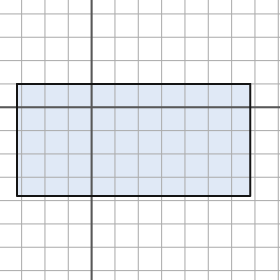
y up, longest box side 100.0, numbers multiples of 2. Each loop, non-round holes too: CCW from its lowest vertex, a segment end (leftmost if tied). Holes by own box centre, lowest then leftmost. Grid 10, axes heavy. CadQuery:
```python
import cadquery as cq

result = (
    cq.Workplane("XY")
    .moveTo(-32.0, -38.0)
    .lineTo(68.0, -38.0)
    .lineTo(68.0, 10.0)
    .lineTo(-32.0, 10.0)
    .close()
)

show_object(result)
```